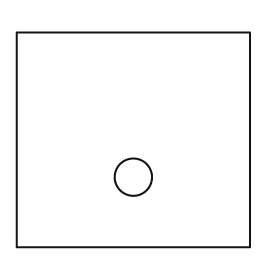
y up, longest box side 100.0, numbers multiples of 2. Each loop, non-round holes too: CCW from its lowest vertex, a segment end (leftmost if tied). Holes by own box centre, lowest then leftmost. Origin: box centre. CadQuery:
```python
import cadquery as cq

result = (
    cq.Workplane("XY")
    .moveTo(-50.0, -46.0)
    .lineTo(50.0, -46.0)
    .lineTo(50.0, 46.0)
    .lineTo(-50.0, 46.0)
    .close()
    .moveTo(0.0, -16.0)
    .circle(8.0)
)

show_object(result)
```